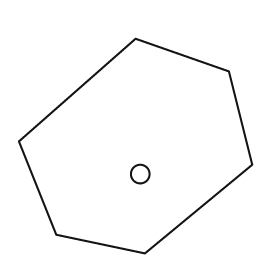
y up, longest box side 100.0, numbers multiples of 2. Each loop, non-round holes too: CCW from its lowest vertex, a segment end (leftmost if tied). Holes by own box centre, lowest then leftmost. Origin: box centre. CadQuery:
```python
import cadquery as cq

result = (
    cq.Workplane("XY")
    .moveTo(4.0, -46.0)
    .lineTo(50.0, -8.0)
    .lineTo(40.0, 32.0)
    .lineTo(0.0, 46.0)
    .lineTo(-50.0, 2.0)
    .lineTo(-34.0, -38.0)
    .close()
    .moveTo(2.0, -12.0)
    .circle(4.0)
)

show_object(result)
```